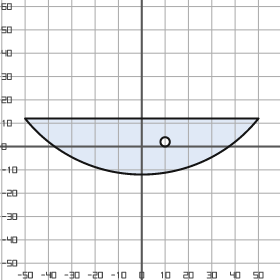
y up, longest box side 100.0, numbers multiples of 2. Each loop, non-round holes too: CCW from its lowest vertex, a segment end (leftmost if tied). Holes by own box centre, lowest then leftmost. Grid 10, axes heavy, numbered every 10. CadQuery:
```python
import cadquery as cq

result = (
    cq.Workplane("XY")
    .moveTo(-50.0, 12.0)
    .threePointArc((0.0, -12.0), (50.0, 12.0))
    .close()
    .moveTo(10.0, 2.0)
    .circle(2.0)
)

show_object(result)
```